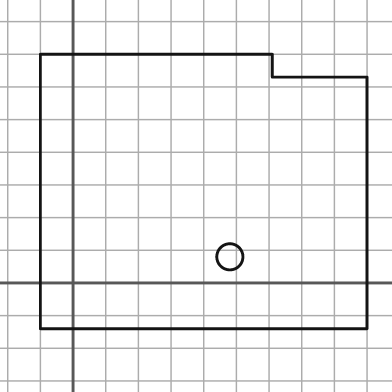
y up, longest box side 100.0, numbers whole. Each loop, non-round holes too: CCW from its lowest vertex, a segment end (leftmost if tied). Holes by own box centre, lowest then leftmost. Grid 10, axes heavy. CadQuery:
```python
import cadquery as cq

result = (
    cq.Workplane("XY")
    .moveTo(-10.0, -14.0)
    .lineTo(90.0, -14.0)
    .lineTo(90.0, 63.0)
    .lineTo(61.0, 63.0)
    .lineTo(61.0, 70.0)
    .lineTo(-10.0, 70.0)
    .close()
    .moveTo(48.0, 8.0)
    .circle(4.0)
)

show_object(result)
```